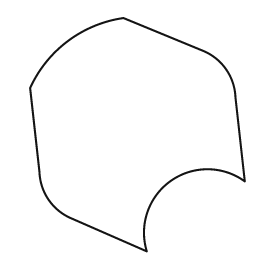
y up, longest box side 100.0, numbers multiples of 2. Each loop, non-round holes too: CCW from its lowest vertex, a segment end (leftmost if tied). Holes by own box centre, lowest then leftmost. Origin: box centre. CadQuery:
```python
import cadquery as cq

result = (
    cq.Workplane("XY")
    .moveTo(4.0, -50.0)
    .threePointArc((14.0, -20.0), (46.0, -20.0))
    .lineTo(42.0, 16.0)
    .threePointArc((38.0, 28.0), (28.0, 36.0))
    .lineTo(-6.0, 50.0)
    .threePointArc((-30.0, 40.0), (-46.0, 20.0))
    .lineTo(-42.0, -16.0)
    .threePointArc((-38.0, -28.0), (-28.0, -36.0))
    .close()
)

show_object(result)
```